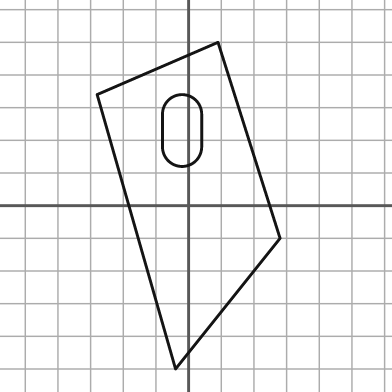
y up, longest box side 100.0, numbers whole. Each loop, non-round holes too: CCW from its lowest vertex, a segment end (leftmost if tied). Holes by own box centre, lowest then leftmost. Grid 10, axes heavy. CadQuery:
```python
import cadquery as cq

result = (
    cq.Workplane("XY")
    .moveTo(-4.0, -50.0)
    .lineTo(28.0, -10.0)
    .lineTo(9.0, 50.0)
    .lineTo(-28.0, 34.0)
    .close()
    .moveTo(-8.0, 18.0)
    .threePointArc((-2.0, 12.0), (4.0, 18.0))
    .lineTo(4.0, 28.0)
    .threePointArc((-2.0, 34.0), (-8.0, 28.0))
    .close()
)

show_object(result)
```